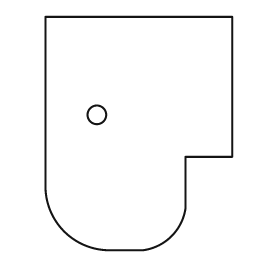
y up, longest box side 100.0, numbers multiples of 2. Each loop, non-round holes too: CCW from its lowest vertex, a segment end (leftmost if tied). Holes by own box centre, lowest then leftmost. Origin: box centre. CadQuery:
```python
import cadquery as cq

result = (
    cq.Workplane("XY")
    .moveTo(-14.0, -50.0)
    .lineTo(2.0, -50.0)
    .threePointArc((14.0, -44.0), (20.0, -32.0))
    .lineTo(20.0, -10.0)
    .lineTo(40.0, -10.0)
    .lineTo(40.0, 50.0)
    .lineTo(-40.0, 50.0)
    .lineTo(-40.0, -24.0)
    .threePointArc((-32.0, -42.0), (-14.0, -50.0))
    .close()
    .moveTo(-18.0, 8.0)
    .circle(4.0)
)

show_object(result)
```